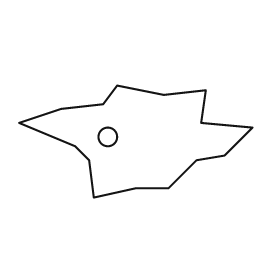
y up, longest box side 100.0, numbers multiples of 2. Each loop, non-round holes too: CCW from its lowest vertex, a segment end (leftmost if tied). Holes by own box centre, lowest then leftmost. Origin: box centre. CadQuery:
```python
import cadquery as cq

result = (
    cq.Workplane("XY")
    .moveTo(-18.0, -24.0)
    .lineTo(0.0, -20.0)
    .lineTo(14.0, -20.0)
    .lineTo(26.0, -8.0)
    .lineTo(38.0, -6.0)
    .lineTo(50.0, 6.0)
    .lineTo(28.0, 8.0)
    .lineTo(30.0, 22.0)
    .lineTo(12.0, 20.0)
    .lineTo(-8.0, 24.0)
    .lineTo(-14.0, 16.0)
    .lineTo(-32.0, 14.0)
    .lineTo(-50.0, 8.0)
    .lineTo(-26.0, -2.0)
    .lineTo(-20.0, -8.0)
    .close()
    .moveTo(-12.0, 2.0)
    .circle(4.0)
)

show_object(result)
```